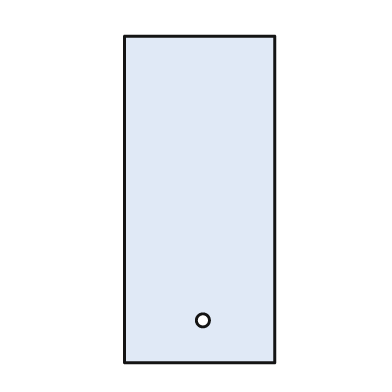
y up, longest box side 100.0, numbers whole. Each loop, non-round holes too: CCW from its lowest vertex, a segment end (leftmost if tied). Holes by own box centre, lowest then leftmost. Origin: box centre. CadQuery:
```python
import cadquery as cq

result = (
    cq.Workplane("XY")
    .moveTo(-23.0, -50.0)
    .lineTo(23.0, -50.0)
    .lineTo(23.0, 50.0)
    .lineTo(-23.0, 50.0)
    .close()
    .moveTo(1.0, -37.0)
    .circle(2.0)
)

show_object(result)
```